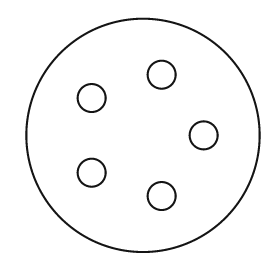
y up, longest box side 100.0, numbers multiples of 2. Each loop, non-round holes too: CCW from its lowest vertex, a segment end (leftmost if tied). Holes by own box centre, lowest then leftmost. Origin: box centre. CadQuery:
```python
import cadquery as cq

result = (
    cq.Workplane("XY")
    .moveTo(0.0, 0.0)
    .circle(50.0)
    .moveTo(8.0, -26.0)
    .circle(6.0)
    .moveTo(-22.0, -16.0)
    .circle(6.0)
    .moveTo(26.0, 0.0)
    .circle(6.0)
    .moveTo(-22.0, 16.0)
    .circle(6.0)
    .moveTo(8.0, 26.0)
    .circle(6.0)
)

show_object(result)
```